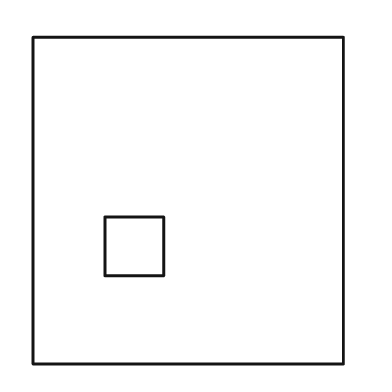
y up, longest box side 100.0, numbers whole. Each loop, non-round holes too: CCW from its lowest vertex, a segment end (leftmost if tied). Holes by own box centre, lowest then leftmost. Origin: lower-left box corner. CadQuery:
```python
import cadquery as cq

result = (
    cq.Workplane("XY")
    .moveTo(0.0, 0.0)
    .lineTo(95.0, 0.0)
    .lineTo(95.0, 100.0)
    .lineTo(0.0, 100.0)
    .close()
    .moveTo(22.0, 27.0)
    .lineTo(40.0, 27.0)
    .lineTo(40.0, 45.0)
    .lineTo(22.0, 45.0)
    .close()
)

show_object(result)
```